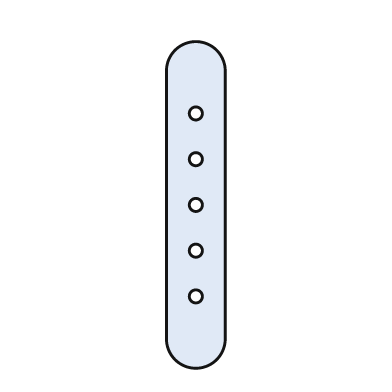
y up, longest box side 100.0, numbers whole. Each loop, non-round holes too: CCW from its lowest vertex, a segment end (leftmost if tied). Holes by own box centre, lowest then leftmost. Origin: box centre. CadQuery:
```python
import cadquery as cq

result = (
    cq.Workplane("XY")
    .moveTo(-9.0, -41.0)
    .threePointArc((0.0, -50.0), (9.0, -41.0))
    .lineTo(9.0, 41.0)
    .threePointArc((0.0, 50.0), (-9.0, 41.0))
    .close()
    .moveTo(0.0, -28.0)
    .circle(2.0)
    .moveTo(0.0, -14.0)
    .circle(2.0)
    .moveTo(0.0, 0.0)
    .circle(2.0)
    .moveTo(0.0, 14.0)
    .circle(2.0)
    .moveTo(0.0, 28.0)
    .circle(2.0)
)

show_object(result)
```